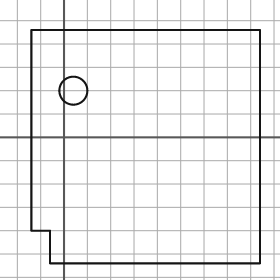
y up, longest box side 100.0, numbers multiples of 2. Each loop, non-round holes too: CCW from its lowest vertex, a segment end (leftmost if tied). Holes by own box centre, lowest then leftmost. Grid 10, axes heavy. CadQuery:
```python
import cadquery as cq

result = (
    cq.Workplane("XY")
    .moveTo(-6.0, -54.0)
    .lineTo(84.0, -54.0)
    .lineTo(84.0, 46.0)
    .lineTo(-14.0, 46.0)
    .lineTo(-14.0, -40.0)
    .lineTo(-6.0, -40.0)
    .close()
    .moveTo(4.0, 20.0)
    .circle(6.0)
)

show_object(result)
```